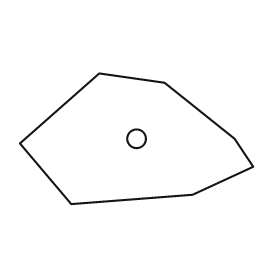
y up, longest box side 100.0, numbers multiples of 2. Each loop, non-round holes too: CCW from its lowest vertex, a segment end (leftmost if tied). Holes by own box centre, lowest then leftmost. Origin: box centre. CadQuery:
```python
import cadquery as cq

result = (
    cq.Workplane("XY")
    .moveTo(-28.0, -28.0)
    .lineTo(24.0, -24.0)
    .lineTo(50.0, -12.0)
    .lineTo(42.0, 0.0)
    .lineTo(12.0, 24.0)
    .lineTo(-16.0, 28.0)
    .lineTo(-50.0, -2.0)
    .close()
    .moveTo(0.0, 0.0)
    .circle(4.0)
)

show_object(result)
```